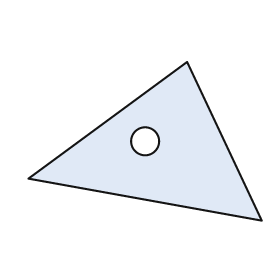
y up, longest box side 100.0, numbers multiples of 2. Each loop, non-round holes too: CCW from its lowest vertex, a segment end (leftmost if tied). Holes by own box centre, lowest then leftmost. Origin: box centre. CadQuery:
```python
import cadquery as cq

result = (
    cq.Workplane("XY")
    .moveTo(50.0, -34.0)
    .lineTo(18.0, 34.0)
    .lineTo(-50.0, -16.0)
    .close()
    .moveTo(0.0, 0.0)
    .circle(6.0)
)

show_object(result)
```